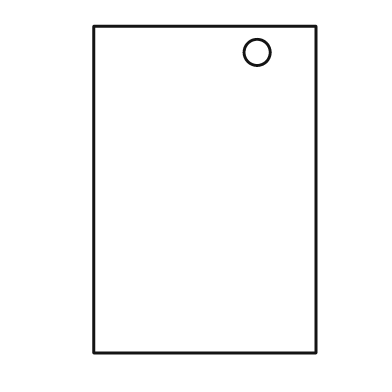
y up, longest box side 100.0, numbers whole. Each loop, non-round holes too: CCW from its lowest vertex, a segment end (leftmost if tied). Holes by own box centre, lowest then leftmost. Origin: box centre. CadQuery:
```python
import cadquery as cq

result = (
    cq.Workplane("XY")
    .moveTo(-34.0, -50.0)
    .lineTo(34.0, -50.0)
    .lineTo(34.0, 50.0)
    .lineTo(-34.0, 50.0)
    .close()
    .moveTo(16.0, 42.0)
    .circle(4.0)
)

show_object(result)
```